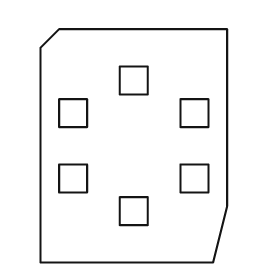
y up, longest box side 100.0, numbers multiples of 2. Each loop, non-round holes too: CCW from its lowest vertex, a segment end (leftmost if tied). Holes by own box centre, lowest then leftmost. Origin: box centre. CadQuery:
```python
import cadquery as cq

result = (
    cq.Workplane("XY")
    .moveTo(-40.0, -50.0)
    .lineTo(34.0, -50.0)
    .lineTo(40.0, -26.0)
    .lineTo(40.0, 50.0)
    .lineTo(-32.0, 50.0)
    .lineTo(-40.0, 42.0)
    .close()
    .moveTo(-6.0, -34.0)
    .lineTo(6.0, -34.0)
    .lineTo(6.0, -22.0)
    .lineTo(-6.0, -22.0)
    .close()
    .moveTo(-32.0, -20.0)
    .lineTo(-20.0, -20.0)
    .lineTo(-20.0, -8.0)
    .lineTo(-32.0, -8.0)
    .close()
    .moveTo(20.0, -20.0)
    .lineTo(32.0, -20.0)
    .lineTo(32.0, -8.0)
    .lineTo(20.0, -8.0)
    .close()
    .moveTo(-32.0, 8.0)
    .lineTo(-20.0, 8.0)
    .lineTo(-20.0, 20.0)
    .lineTo(-32.0, 20.0)
    .close()
    .moveTo(20.0, 8.0)
    .lineTo(32.0, 8.0)
    .lineTo(32.0, 20.0)
    .lineTo(20.0, 20.0)
    .close()
    .moveTo(-6.0, 22.0)
    .lineTo(6.0, 22.0)
    .lineTo(6.0, 34.0)
    .lineTo(-6.0, 34.0)
    .close()
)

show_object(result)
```